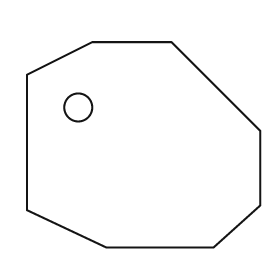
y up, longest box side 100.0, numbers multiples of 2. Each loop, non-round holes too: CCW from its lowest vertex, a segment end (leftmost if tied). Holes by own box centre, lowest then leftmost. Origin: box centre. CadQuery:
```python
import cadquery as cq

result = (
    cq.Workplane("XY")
    .moveTo(-16.0, -44.0)
    .lineTo(30.0, -44.0)
    .lineTo(50.0, -26.0)
    .lineTo(50.0, 6.0)
    .lineTo(12.0, 44.0)
    .lineTo(-22.0, 44.0)
    .lineTo(-50.0, 30.0)
    .lineTo(-50.0, -28.0)
    .close()
    .moveTo(-28.0, 16.0)
    .circle(6.0)
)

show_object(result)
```